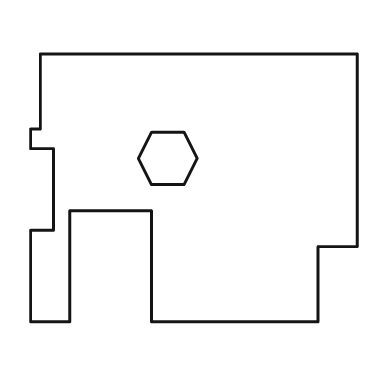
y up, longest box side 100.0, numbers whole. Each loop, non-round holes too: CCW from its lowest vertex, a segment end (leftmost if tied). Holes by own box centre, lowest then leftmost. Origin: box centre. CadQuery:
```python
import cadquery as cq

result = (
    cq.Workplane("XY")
    .moveTo(-50.0, -41.0)
    .lineTo(-38.0, -41.0)
    .lineTo(-38.0, -7.0)
    .lineTo(-13.0, -7.0)
    .lineTo(-13.0, -41.0)
    .lineTo(38.0, -41.0)
    .lineTo(38.0, -18.0)
    .lineTo(50.0, -18.0)
    .lineTo(50.0, 41.0)
    .lineTo(-47.0, 41.0)
    .lineTo(-47.0, 18.0)
    .lineTo(-50.0, 18.0)
    .lineTo(-50.0, 12.0)
    .lineTo(-43.0, 12.0)
    .lineTo(-43.0, -13.0)
    .lineTo(-50.0, -13.0)
    .close()
    .moveTo(-13.0, 1.0)
    .lineTo(-3.0, 1.0)
    .lineTo(1.0, 9.0)
    .lineTo(-3.0, 17.0)
    .lineTo(-13.0, 17.0)
    .lineTo(-17.0, 9.0)
    .close()
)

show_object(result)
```